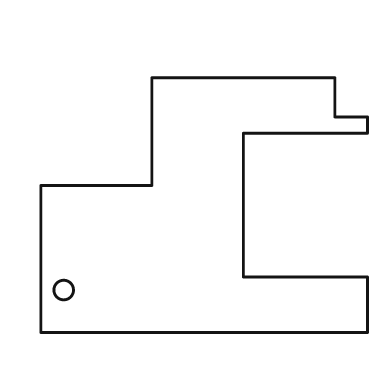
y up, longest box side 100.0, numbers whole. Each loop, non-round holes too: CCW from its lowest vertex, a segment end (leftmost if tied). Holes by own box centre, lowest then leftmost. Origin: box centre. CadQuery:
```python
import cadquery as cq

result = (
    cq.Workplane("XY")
    .moveTo(-50.0, -39.0)
    .lineTo(50.0, -39.0)
    .lineTo(50.0, -22.0)
    .lineTo(12.0, -22.0)
    .lineTo(12.0, 22.0)
    .lineTo(50.0, 22.0)
    .lineTo(50.0, 27.0)
    .lineTo(40.0, 27.0)
    .lineTo(40.0, 39.0)
    .lineTo(-16.0, 39.0)
    .lineTo(-16.0, 6.0)
    .lineTo(-50.0, 6.0)
    .close()
    .moveTo(-43.0, -26.0)
    .circle(3.0)
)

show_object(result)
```